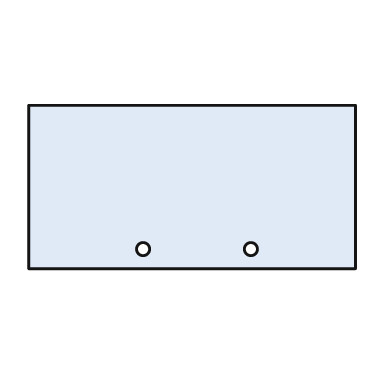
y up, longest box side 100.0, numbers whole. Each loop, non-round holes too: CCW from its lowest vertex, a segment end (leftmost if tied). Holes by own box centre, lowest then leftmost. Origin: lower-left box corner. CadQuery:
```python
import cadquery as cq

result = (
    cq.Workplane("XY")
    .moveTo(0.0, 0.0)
    .lineTo(100.0, 0.0)
    .lineTo(100.0, 50.0)
    .lineTo(0.0, 50.0)
    .close()
    .moveTo(35.0, 6.0)
    .circle(2.0)
    .moveTo(68.0, 6.0)
    .circle(2.0)
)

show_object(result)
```